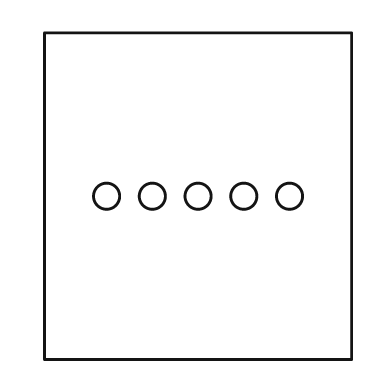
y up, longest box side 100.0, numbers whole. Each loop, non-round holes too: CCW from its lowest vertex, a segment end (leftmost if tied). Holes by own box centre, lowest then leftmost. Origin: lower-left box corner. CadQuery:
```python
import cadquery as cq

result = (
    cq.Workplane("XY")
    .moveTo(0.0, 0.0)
    .lineTo(94.0, 0.0)
    .lineTo(94.0, 100.0)
    .lineTo(0.0, 100.0)
    .close()
    .moveTo(19.0, 50.0)
    .circle(4.0)
    .moveTo(33.0, 50.0)
    .circle(4.0)
    .moveTo(47.0, 50.0)
    .circle(4.0)
    .moveTo(61.0, 50.0)
    .circle(4.0)
    .moveTo(75.0, 50.0)
    .circle(4.0)
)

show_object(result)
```